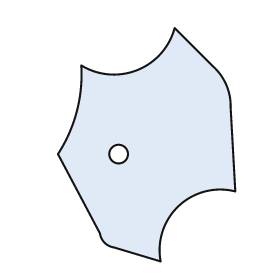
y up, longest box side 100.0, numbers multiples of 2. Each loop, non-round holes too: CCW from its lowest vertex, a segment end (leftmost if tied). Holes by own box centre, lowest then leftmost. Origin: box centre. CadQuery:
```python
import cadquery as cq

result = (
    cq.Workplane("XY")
    .moveTo(6.0, -50.0)
    .threePointArc((14.0, -26.0), (38.0, -20.0))
    .lineTo(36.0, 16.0)
    .threePointArc((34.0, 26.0), (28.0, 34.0))
    .lineTo(12.0, 50.0)
    .threePointArc((-4.0, 32.0), (-28.0, 34.0))
    .threePointArc((-30.0, 14.0), (-38.0, -4.0))
    .lineTo(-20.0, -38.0)
    .threePointArc((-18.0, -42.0), (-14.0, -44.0))
    .close()
    .moveTo(-12.0, -4.0)
    .circle(4.0)
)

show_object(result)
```